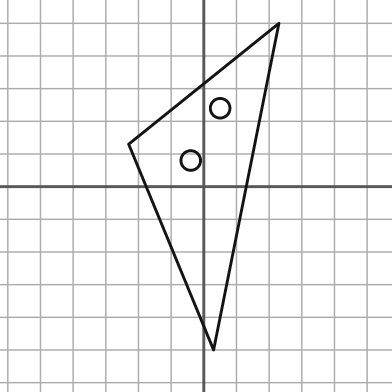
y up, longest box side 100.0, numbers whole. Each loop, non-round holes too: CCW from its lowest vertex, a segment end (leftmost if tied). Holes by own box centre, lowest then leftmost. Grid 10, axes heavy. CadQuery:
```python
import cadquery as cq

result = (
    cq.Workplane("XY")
    .moveTo(3.0, -50.0)
    .lineTo(23.0, 50.0)
    .lineTo(-23.0, 13.0)
    .close()
    .moveTo(-4.0, 8.0)
    .circle(3.0)
    .moveTo(5.0, 24.0)
    .circle(3.0)
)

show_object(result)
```